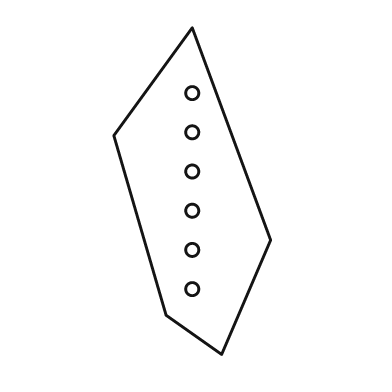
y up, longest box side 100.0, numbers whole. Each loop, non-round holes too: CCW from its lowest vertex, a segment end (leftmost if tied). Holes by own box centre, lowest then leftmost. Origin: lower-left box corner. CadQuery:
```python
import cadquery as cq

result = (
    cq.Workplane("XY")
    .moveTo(33.0, 0.0)
    .lineTo(48.0, 35.0)
    .lineTo(24.0, 100.0)
    .lineTo(0.0, 67.0)
    .lineTo(16.0, 12.0)
    .close()
    .moveTo(24.0, 20.0)
    .circle(2.0)
    .moveTo(24.0, 32.0)
    .circle(2.0)
    .moveTo(24.0, 44.0)
    .circle(2.0)
    .moveTo(24.0, 56.0)
    .circle(2.0)
    .moveTo(24.0, 68.0)
    .circle(2.0)
    .moveTo(24.0, 80.0)
    .circle(2.0)
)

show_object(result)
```